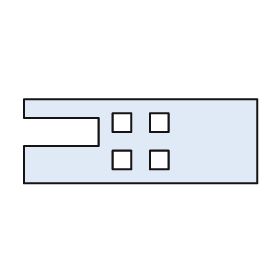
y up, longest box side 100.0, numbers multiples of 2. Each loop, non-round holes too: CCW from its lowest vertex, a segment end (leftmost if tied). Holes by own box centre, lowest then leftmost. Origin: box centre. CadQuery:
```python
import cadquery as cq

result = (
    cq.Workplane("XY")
    .moveTo(-50.0, -18.0)
    .lineTo(50.0, -18.0)
    .lineTo(50.0, 18.0)
    .lineTo(-50.0, 18.0)
    .lineTo(-50.0, 10.0)
    .lineTo(-18.0, 10.0)
    .lineTo(-18.0, -2.0)
    .lineTo(-50.0, -2.0)
    .close()
    .moveTo(-12.0, -12.0)
    .lineTo(-4.0, -12.0)
    .lineTo(-4.0, -4.0)
    .lineTo(-12.0, -4.0)
    .close()
    .moveTo(4.0, -12.0)
    .lineTo(12.0, -12.0)
    .lineTo(12.0, -4.0)
    .lineTo(4.0, -4.0)
    .close()
    .moveTo(-12.0, 4.0)
    .lineTo(-4.0, 4.0)
    .lineTo(-4.0, 12.0)
    .lineTo(-12.0, 12.0)
    .close()
    .moveTo(4.0, 4.0)
    .lineTo(12.0, 4.0)
    .lineTo(12.0, 12.0)
    .lineTo(4.0, 12.0)
    .close()
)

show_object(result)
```